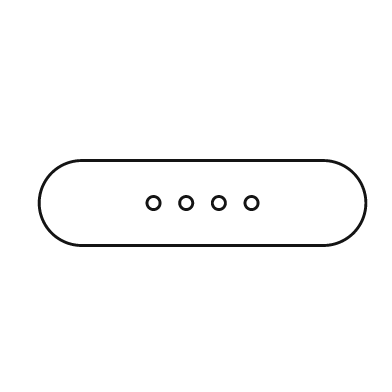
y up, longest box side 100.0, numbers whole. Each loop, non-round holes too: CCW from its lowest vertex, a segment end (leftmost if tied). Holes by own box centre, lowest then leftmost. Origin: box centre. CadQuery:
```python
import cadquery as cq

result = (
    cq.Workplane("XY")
    .moveTo(-37.0, -13.0)
    .lineTo(37.0, -13.0)
    .threePointArc((50.0, 0.0), (37.0, 13.0))
    .lineTo(-37.0, 13.0)
    .threePointArc((-50.0, 0.0), (-37.0, -13.0))
    .close()
    .moveTo(-15.0, 0.0)
    .circle(2.0)
    .moveTo(-5.0, 0.0)
    .circle(2.0)
    .moveTo(5.0, 0.0)
    .circle(2.0)
    .moveTo(15.0, 0.0)
    .circle(2.0)
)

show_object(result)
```